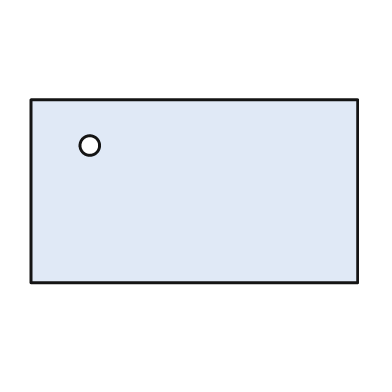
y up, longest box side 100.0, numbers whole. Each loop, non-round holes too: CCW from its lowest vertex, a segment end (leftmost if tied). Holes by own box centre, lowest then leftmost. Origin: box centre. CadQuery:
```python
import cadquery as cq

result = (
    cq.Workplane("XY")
    .moveTo(-50.0, -28.0)
    .lineTo(50.0, -28.0)
    .lineTo(50.0, 28.0)
    .lineTo(-50.0, 28.0)
    .close()
    .moveTo(-32.0, 14.0)
    .circle(3.0)
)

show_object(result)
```